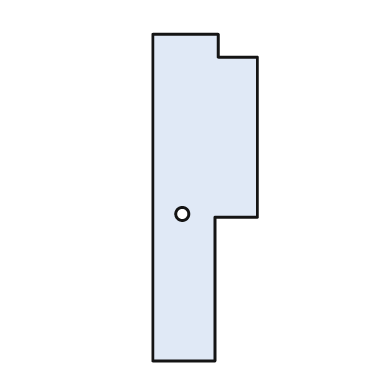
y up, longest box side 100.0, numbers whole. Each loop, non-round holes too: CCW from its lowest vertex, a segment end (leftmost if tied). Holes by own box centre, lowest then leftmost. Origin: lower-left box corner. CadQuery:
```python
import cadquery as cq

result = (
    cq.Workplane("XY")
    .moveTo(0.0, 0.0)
    .lineTo(19.0, 0.0)
    .lineTo(19.0, 44.0)
    .lineTo(32.0, 44.0)
    .lineTo(32.0, 93.0)
    .lineTo(20.0, 93.0)
    .lineTo(20.0, 100.0)
    .lineTo(0.0, 100.0)
    .close()
    .moveTo(9.0, 45.0)
    .circle(2.0)
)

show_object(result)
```